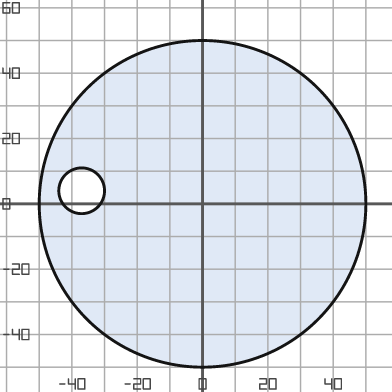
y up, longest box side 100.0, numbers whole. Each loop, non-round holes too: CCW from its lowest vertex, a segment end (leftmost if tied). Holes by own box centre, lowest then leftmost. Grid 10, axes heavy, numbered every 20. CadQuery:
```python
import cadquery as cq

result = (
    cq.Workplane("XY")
    .moveTo(0.0, 0.0)
    .circle(50.0)
    .moveTo(-37.0, 4.0)
    .circle(7.0)
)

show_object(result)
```